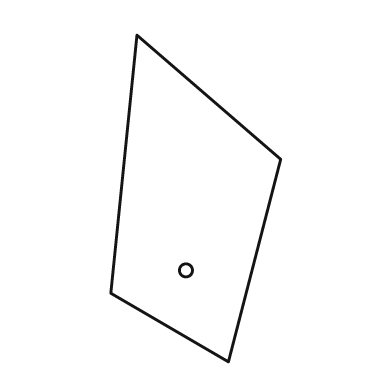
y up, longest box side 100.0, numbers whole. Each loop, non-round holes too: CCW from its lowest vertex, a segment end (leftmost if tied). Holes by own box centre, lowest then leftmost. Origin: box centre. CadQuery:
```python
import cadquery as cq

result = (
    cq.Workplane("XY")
    .moveTo(10.0, -50.0)
    .lineTo(26.0, 12.0)
    .lineTo(-18.0, 50.0)
    .lineTo(-26.0, -29.0)
    .close()
    .moveTo(-3.0, -22.0)
    .circle(2.0)
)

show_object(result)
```